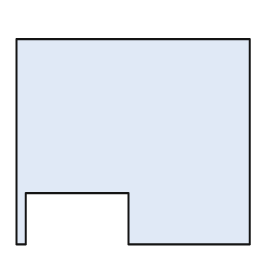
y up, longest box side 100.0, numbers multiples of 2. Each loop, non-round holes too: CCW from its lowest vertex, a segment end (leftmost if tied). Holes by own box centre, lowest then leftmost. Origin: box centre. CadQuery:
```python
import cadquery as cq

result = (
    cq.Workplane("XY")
    .moveTo(-50.0, -44.0)
    .lineTo(-46.0, -44.0)
    .lineTo(-46.0, -22.0)
    .lineTo(-2.0, -22.0)
    .lineTo(-2.0, -44.0)
    .lineTo(50.0, -44.0)
    .lineTo(50.0, 44.0)
    .lineTo(-50.0, 44.0)
    .close()
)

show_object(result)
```